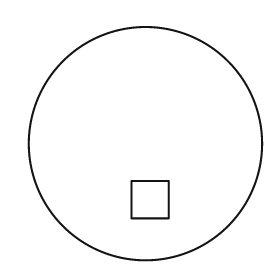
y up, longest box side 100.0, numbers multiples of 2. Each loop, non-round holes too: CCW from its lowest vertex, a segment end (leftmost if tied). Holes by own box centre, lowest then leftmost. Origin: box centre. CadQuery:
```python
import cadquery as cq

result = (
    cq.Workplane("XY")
    .moveTo(0.0, 0.0)
    .circle(50.0)
    .moveTo(-6.0, -32.0)
    .lineTo(10.0, -32.0)
    .lineTo(10.0, -16.0)
    .lineTo(-6.0, -16.0)
    .close()
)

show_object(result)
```